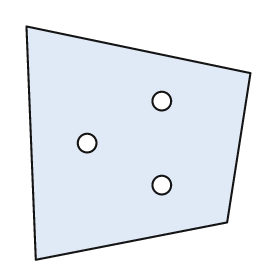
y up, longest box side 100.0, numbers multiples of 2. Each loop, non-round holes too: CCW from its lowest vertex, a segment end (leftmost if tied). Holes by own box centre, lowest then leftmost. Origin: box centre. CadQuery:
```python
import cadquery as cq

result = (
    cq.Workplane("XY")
    .moveTo(-44.0, -50.0)
    .lineTo(38.0, -34.0)
    .lineTo(48.0, 30.0)
    .lineTo(-48.0, 50.0)
    .close()
    .moveTo(10.0, -18.0)
    .circle(4.0)
    .moveTo(-22.0, 0.0)
    .circle(4.0)
    .moveTo(10.0, 18.0)
    .circle(4.0)
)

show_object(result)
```